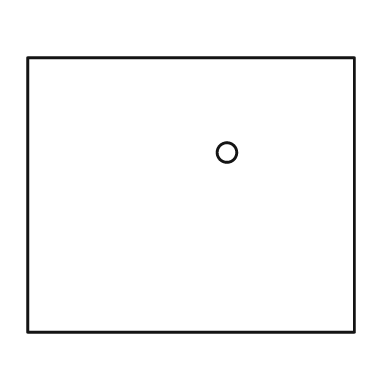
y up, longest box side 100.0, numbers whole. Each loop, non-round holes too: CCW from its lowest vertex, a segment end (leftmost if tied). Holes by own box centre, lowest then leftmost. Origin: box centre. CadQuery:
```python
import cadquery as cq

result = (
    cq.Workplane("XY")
    .moveTo(-50.0, -42.0)
    .lineTo(50.0, -42.0)
    .lineTo(50.0, 42.0)
    .lineTo(-50.0, 42.0)
    .close()
    .moveTo(11.0, 13.0)
    .circle(3.0)
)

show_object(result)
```